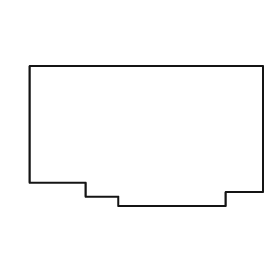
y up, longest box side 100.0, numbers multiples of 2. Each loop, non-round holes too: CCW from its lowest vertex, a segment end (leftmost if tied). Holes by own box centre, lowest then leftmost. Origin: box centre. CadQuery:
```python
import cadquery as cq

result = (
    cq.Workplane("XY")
    .moveTo(-12.0, -30.0)
    .lineTo(34.0, -30.0)
    .lineTo(34.0, -24.0)
    .lineTo(50.0, -24.0)
    .lineTo(50.0, 30.0)
    .lineTo(-50.0, 30.0)
    .lineTo(-50.0, -20.0)
    .lineTo(-26.0, -20.0)
    .lineTo(-26.0, -26.0)
    .lineTo(-12.0, -26.0)
    .close()
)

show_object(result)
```